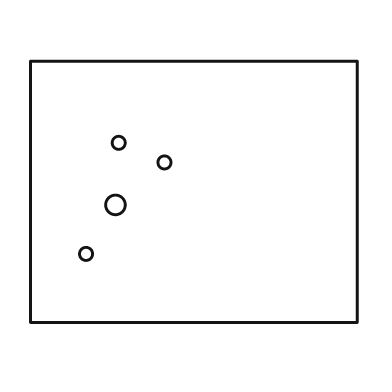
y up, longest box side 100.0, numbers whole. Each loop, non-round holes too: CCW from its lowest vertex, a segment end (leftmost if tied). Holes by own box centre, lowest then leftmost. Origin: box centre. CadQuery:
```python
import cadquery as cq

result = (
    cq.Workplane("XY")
    .moveTo(-50.0, -40.0)
    .lineTo(50.0, -40.0)
    .lineTo(50.0, 40.0)
    .lineTo(-50.0, 40.0)
    .close()
    .moveTo(-33.0, -19.0)
    .circle(2.0)
    .moveTo(-24.0, -4.0)
    .circle(3.0)
    .moveTo(-9.0, 9.0)
    .circle(2.0)
    .moveTo(-23.0, 15.0)
    .circle(2.0)
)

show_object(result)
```